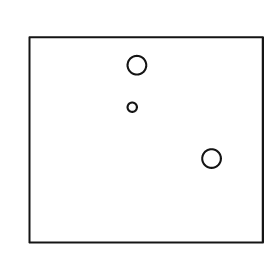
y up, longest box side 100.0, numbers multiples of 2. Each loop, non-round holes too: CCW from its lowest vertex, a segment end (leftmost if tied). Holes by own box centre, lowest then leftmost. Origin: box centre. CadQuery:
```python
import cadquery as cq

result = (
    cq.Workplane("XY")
    .moveTo(-50.0, -44.0)
    .lineTo(50.0, -44.0)
    .lineTo(50.0, 44.0)
    .lineTo(-50.0, 44.0)
    .close()
    .moveTo(28.0, -8.0)
    .circle(4.0)
    .moveTo(-6.0, 14.0)
    .circle(2.0)
    .moveTo(-4.0, 32.0)
    .circle(4.0)
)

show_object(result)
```